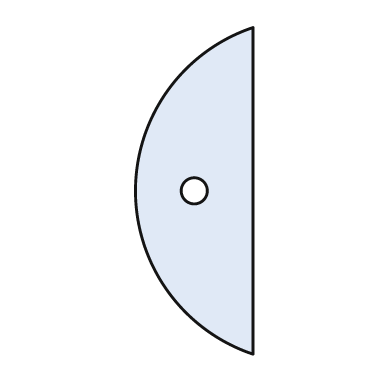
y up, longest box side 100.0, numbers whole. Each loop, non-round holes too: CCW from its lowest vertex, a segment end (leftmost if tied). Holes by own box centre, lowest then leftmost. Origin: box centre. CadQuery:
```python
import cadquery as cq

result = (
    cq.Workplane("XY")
    .moveTo(18.0, -50.0)
    .lineTo(18.0, 50.0)
    .threePointArc((-18.0, 0.0), (18.0, -50.0))
    .close()
    .moveTo(0.0, 0.0)
    .circle(4.0)
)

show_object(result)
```